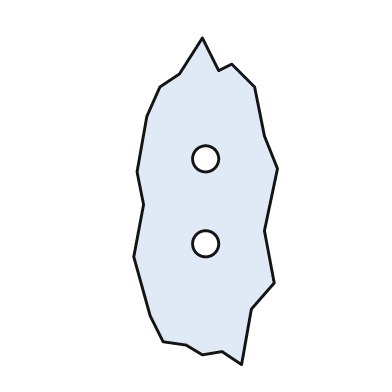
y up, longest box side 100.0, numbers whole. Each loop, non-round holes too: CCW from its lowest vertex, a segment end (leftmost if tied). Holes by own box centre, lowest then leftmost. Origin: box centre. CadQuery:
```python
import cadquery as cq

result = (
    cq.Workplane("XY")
    .moveTo(11.0, -50.0)
    .lineTo(14.0, -33.0)
    .lineTo(21.0, -25.0)
    .lineTo(18.0, -9.0)
    .lineTo(22.0, 10.0)
    .lineTo(18.0, 20.0)
    .lineTo(15.0, 35.0)
    .lineTo(8.0, 42.0)
    .lineTo(4.0, 40.0)
    .lineTo(-1.0, 50.0)
    .lineTo(-8.0, 39.0)
    .lineTo(-14.0, 35.0)
    .lineTo(-18.0, 26.0)
    .lineTo(-21.0, 9.0)
    .lineTo(-19.0, -1.0)
    .lineTo(-22.0, -17.0)
    .lineTo(-17.0, -35.0)
    .lineTo(-13.0, -43.0)
    .lineTo(-6.0, -44.0)
    .lineTo(-1.0, -47.0)
    .lineTo(5.0, -46.0)
    .close()
    .moveTo(0.0, -13.0)
    .circle(4.0)
    .moveTo(0.0, 13.0)
    .circle(4.0)
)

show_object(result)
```